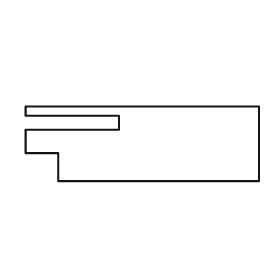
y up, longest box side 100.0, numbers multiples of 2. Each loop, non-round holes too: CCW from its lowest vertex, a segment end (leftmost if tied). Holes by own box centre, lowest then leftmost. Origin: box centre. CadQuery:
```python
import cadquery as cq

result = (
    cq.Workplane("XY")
    .moveTo(-36.0, -16.0)
    .lineTo(50.0, -16.0)
    .lineTo(50.0, 16.0)
    .lineTo(-50.0, 16.0)
    .lineTo(-50.0, 12.0)
    .lineTo(-10.0, 12.0)
    .lineTo(-10.0, 6.0)
    .lineTo(-50.0, 6.0)
    .lineTo(-50.0, -4.0)
    .lineTo(-36.0, -4.0)
    .close()
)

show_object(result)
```